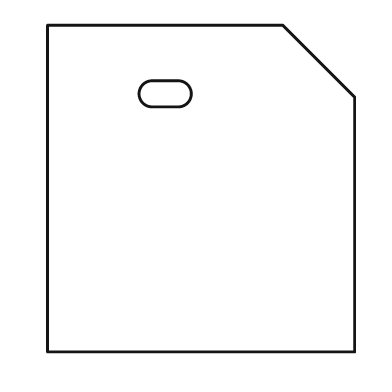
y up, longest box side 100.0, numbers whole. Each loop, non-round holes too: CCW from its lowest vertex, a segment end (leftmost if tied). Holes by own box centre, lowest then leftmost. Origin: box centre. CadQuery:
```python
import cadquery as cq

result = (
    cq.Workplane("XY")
    .moveTo(-47.0, -50.0)
    .lineTo(47.0, -50.0)
    .lineTo(47.0, 28.0)
    .lineTo(25.0, 50.0)
    .lineTo(-47.0, 50.0)
    .close()
    .moveTo(-15.0, 25.0)
    .lineTo(-7.0, 25.0)
    .threePointArc((-3.0, 29.0), (-7.0, 33.0))
    .lineTo(-15.0, 33.0)
    .threePointArc((-19.0, 29.0), (-15.0, 25.0))
    .close()
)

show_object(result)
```